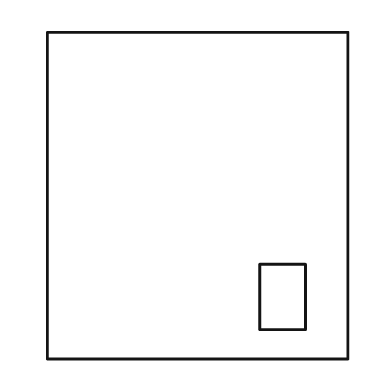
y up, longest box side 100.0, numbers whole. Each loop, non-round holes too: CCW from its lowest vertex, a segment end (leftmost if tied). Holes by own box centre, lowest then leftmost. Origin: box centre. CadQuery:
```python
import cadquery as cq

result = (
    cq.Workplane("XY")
    .moveTo(-46.0, -50.0)
    .lineTo(46.0, -50.0)
    .lineTo(46.0, 50.0)
    .lineTo(-46.0, 50.0)
    .close()
    .moveTo(19.0, -41.0)
    .lineTo(33.0, -41.0)
    .lineTo(33.0, -21.0)
    .lineTo(19.0, -21.0)
    .close()
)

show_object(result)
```